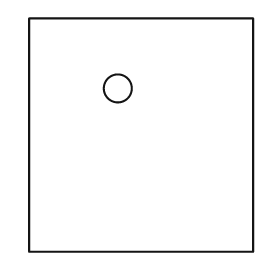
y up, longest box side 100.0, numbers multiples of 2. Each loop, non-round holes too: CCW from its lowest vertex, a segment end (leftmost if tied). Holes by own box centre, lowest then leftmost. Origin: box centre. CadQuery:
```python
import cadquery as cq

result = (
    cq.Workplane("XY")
    .moveTo(-48.0, -50.0)
    .lineTo(48.0, -50.0)
    .lineTo(48.0, 50.0)
    .lineTo(-48.0, 50.0)
    .close()
    .moveTo(-10.0, 20.0)
    .circle(6.0)
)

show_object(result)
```